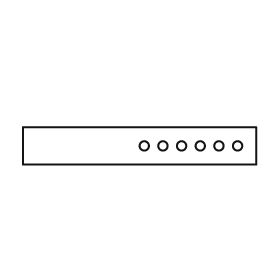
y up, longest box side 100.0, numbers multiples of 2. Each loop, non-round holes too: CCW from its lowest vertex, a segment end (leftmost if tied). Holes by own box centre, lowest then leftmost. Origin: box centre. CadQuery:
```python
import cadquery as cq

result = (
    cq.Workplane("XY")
    .moveTo(-50.0, -8.0)
    .lineTo(50.0, -8.0)
    .lineTo(50.0, 8.0)
    .lineTo(-50.0, 8.0)
    .close()
    .moveTo(2.0, 0.0)
    .circle(2.0)
    .moveTo(10.0, 0.0)
    .circle(2.0)
    .moveTo(18.0, 0.0)
    .circle(2.0)
    .moveTo(26.0, 0.0)
    .circle(2.0)
    .moveTo(34.0, 0.0)
    .circle(2.0)
    .moveTo(42.0, 0.0)
    .circle(2.0)
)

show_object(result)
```